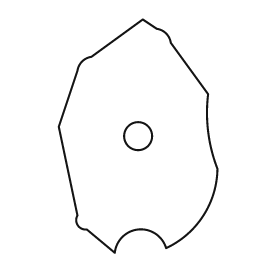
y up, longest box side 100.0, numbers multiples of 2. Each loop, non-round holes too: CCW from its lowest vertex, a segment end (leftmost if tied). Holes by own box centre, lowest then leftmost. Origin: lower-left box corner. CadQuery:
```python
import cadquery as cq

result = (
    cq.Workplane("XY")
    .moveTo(24.0, 0.0)
    .threePointArc((34.0, 10.0), (46.0, 2.0))
    .threePointArc((62.0, 16.0), (68.0, 36.0))
    .threePointArc((64.0, 52.0), (64.0, 68.0))
    .lineTo(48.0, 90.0)
    .threePointArc((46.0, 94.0), (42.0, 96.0))
    .lineTo(36.0, 100.0)
    .lineTo(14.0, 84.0)
    .threePointArc((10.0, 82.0), (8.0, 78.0))
    .lineTo(0.0, 54.0)
    .lineTo(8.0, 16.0)
    .threePointArc((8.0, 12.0), (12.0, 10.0))
    .close()
    .moveTo(34.0, 50.0)
    .circle(6.0)
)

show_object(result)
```